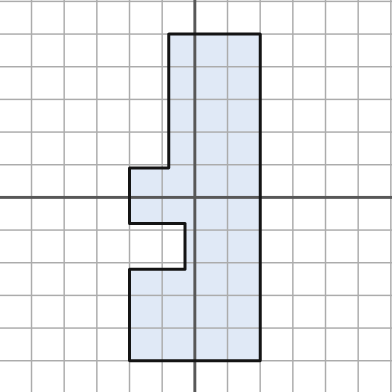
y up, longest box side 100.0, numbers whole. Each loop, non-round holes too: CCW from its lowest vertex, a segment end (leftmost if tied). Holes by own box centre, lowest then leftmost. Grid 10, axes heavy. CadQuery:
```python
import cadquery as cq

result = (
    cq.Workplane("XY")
    .moveTo(-20.0, -50.0)
    .lineTo(20.0, -50.0)
    .lineTo(20.0, 50.0)
    .lineTo(-8.0, 50.0)
    .lineTo(-8.0, 9.0)
    .lineTo(-20.0, 9.0)
    .lineTo(-20.0, -8.0)
    .lineTo(-3.0, -8.0)
    .lineTo(-3.0, -22.0)
    .lineTo(-20.0, -22.0)
    .close()
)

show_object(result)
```